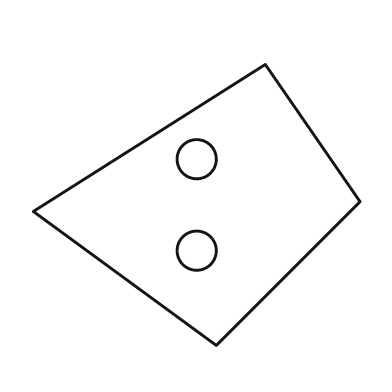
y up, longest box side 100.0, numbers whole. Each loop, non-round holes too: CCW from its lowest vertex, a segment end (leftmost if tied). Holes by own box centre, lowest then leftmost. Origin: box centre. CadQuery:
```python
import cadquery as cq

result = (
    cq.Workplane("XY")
    .moveTo(6.0, -43.0)
    .lineTo(50.0, 1.0)
    .lineTo(21.0, 43.0)
    .lineTo(-50.0, -2.0)
    .close()
    .moveTo(0.0, -14.0)
    .circle(6.0)
    .moveTo(0.0, 14.0)
    .circle(6.0)
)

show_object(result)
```